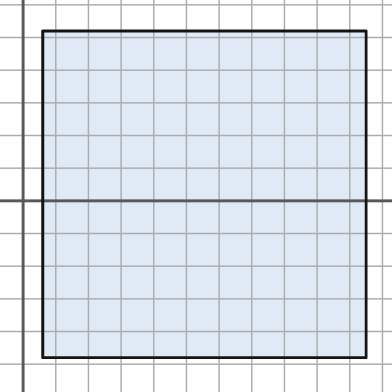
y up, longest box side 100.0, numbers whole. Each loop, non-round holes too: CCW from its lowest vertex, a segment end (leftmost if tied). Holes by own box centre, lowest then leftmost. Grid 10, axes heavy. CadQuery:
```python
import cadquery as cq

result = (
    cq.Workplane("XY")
    .moveTo(6.0, -48.0)
    .lineTo(105.0, -48.0)
    .lineTo(105.0, 52.0)
    .lineTo(6.0, 52.0)
    .close()
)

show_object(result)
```